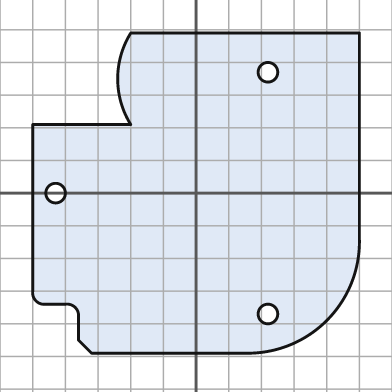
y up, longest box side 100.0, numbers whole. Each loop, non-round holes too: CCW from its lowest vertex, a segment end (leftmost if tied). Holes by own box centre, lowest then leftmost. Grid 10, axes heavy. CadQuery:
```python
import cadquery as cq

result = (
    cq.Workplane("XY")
    .moveTo(-32.0, -49.0)
    .lineTo(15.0, -49.0)
    .threePointArc((40.0, -39.0), (50.0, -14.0))
    .lineTo(50.0, 49.0)
    .lineTo(-20.0, 49.0)
    .threePointArc((-24.0, 35.0), (-20.0, 21.0))
    .lineTo(-50.0, 21.0)
    .lineTo(-50.0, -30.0)
    .threePointArc((-49.0, -33.0), (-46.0, -34.0))
    .lineTo(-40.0, -34.0)
    .threePointArc((-37.0, -35.0), (-36.0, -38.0))
    .lineTo(-36.0, -45.0)
    .close()
    .moveTo(22.0, -37.0)
    .circle(3.0)
    .moveTo(-43.0, 0.0)
    .circle(3.0)
    .moveTo(22.0, 37.0)
    .circle(3.0)
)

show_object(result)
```